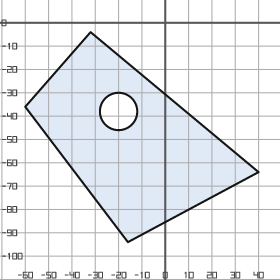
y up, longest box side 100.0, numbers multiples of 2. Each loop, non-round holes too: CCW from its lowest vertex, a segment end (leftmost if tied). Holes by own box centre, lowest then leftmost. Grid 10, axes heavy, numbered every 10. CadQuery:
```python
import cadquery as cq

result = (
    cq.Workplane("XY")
    .moveTo(-16.0, -94.0)
    .lineTo(40.0, -64.0)
    .lineTo(-32.0, -4.0)
    .lineTo(-60.0, -36.0)
    .close()
    .moveTo(-20.0, -38.0)
    .circle(8.0)
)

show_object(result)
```